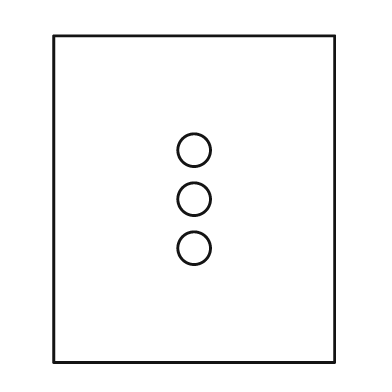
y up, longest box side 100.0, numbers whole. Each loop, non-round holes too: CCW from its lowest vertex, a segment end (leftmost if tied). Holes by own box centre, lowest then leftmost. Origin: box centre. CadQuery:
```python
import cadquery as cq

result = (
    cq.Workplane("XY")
    .moveTo(-43.0, -50.0)
    .lineTo(43.0, -50.0)
    .lineTo(43.0, 50.0)
    .lineTo(-43.0, 50.0)
    .close()
    .moveTo(0.0, -15.0)
    .circle(5.0)
    .moveTo(0.0, 0.0)
    .circle(5.0)
    .moveTo(0.0, 15.0)
    .circle(5.0)
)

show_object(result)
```